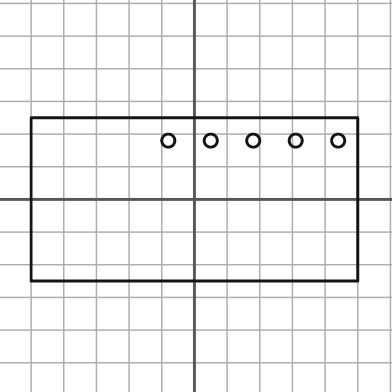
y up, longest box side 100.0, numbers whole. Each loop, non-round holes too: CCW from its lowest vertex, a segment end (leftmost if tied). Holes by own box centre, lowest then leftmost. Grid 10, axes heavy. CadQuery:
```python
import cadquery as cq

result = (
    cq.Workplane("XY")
    .moveTo(-50.0, -25.0)
    .lineTo(50.0, -25.0)
    .lineTo(50.0, 25.0)
    .lineTo(-50.0, 25.0)
    .close()
    .moveTo(-8.0, 18.0)
    .circle(2.0)
    .moveTo(5.0, 18.0)
    .circle(2.0)
    .moveTo(18.0, 18.0)
    .circle(2.0)
    .moveTo(31.0, 18.0)
    .circle(2.0)
    .moveTo(44.0, 18.0)
    .circle(2.0)
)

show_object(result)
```